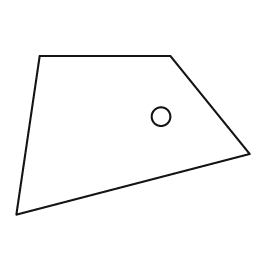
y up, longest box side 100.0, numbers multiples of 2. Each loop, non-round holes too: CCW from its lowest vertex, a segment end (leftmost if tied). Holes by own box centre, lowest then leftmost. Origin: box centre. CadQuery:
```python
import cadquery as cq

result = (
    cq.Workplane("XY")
    .moveTo(-50.0, -34.0)
    .lineTo(50.0, -8.0)
    .lineTo(16.0, 34.0)
    .lineTo(-40.0, 34.0)
    .close()
    .moveTo(12.0, 8.0)
    .circle(4.0)
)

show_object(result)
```